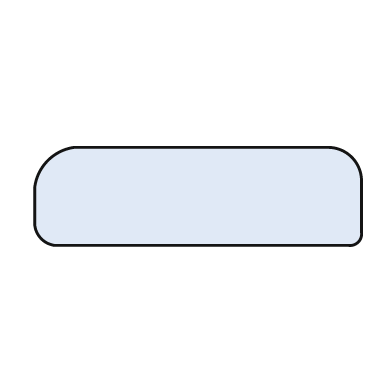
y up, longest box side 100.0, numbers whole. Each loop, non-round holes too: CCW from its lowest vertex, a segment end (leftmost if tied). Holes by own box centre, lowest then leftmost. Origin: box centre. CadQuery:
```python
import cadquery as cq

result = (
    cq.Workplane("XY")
    .moveTo(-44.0, -15.0)
    .lineTo(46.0, -15.0)
    .threePointArc((49.0, -14.0), (50.0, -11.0))
    .lineTo(50.0, 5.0)
    .threePointArc((47.0, 12.0), (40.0, 15.0))
    .lineTo(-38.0, 15.0)
    .threePointArc((-46.0, 11.0), (-50.0, 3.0))
    .lineTo(-50.0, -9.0)
    .threePointArc((-48.0, -13.0), (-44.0, -15.0))
    .close()
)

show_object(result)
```